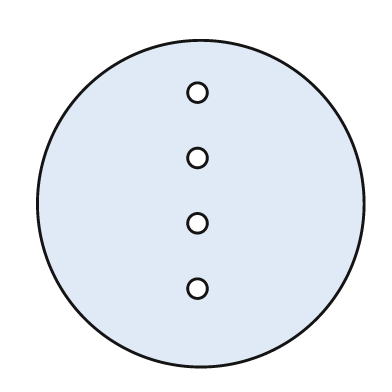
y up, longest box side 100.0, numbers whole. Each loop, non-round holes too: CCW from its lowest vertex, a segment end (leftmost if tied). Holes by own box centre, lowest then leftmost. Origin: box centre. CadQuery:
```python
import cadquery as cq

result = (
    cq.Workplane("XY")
    .moveTo(0.0, 0.0)
    .circle(50.0)
    .moveTo(-1.0, -26.0)
    .circle(3.0)
    .moveTo(-1.0, -6.0)
    .circle(3.0)
    .moveTo(-1.0, 14.0)
    .circle(3.0)
    .moveTo(-1.0, 34.0)
    .circle(3.0)
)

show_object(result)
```